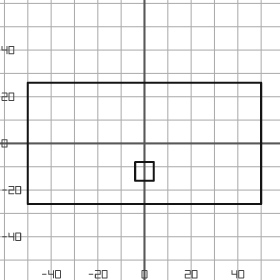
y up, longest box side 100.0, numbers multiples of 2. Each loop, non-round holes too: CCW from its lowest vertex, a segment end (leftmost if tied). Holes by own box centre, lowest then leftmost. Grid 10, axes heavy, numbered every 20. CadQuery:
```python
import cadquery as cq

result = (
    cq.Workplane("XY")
    .moveTo(-50.0, -26.0)
    .lineTo(50.0, -26.0)
    .lineTo(50.0, 26.0)
    .lineTo(-50.0, 26.0)
    .close()
    .moveTo(-4.0, -16.0)
    .lineTo(4.0, -16.0)
    .lineTo(4.0, -8.0)
    .lineTo(-4.0, -8.0)
    .close()
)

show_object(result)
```